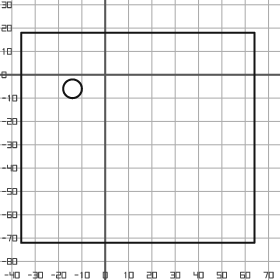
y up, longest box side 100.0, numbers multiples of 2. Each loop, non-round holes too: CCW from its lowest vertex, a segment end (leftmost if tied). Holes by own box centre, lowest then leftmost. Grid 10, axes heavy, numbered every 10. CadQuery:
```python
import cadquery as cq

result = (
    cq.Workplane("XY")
    .moveTo(-36.0, -72.0)
    .lineTo(64.0, -72.0)
    .lineTo(64.0, 18.0)
    .lineTo(-36.0, 18.0)
    .close()
    .moveTo(-14.0, -6.0)
    .circle(4.0)
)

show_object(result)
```